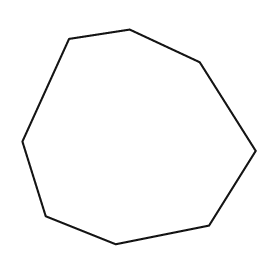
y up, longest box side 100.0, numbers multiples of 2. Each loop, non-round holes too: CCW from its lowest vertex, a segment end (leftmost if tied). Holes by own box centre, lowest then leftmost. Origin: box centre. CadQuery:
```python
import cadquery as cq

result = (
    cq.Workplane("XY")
    .moveTo(-10.0, -46.0)
    .lineTo(30.0, -38.0)
    .lineTo(50.0, -6.0)
    .lineTo(26.0, 32.0)
    .lineTo(-4.0, 46.0)
    .lineTo(-30.0, 42.0)
    .lineTo(-50.0, -2.0)
    .lineTo(-40.0, -34.0)
    .close()
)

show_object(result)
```